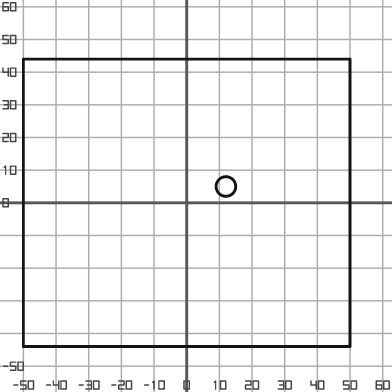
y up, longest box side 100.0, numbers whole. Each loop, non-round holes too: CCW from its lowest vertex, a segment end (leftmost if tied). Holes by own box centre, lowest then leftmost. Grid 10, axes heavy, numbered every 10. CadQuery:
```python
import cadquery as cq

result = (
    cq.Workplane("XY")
    .moveTo(-50.0, -44.0)
    .lineTo(50.0, -44.0)
    .lineTo(50.0, 44.0)
    .lineTo(-50.0, 44.0)
    .close()
    .moveTo(12.0, 5.0)
    .circle(3.0)
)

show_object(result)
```